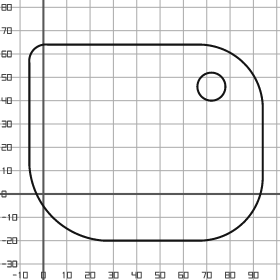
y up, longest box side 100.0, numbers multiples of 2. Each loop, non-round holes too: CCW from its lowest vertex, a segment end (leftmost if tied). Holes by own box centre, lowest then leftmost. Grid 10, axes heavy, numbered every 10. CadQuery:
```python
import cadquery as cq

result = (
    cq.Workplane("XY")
    .moveTo(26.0, -20.0)
    .lineTo(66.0, -20.0)
    .threePointArc((86.0, -12.0), (94.0, 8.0))
    .lineTo(94.0, 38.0)
    .threePointArc((86.0, 56.0), (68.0, 64.0))
    .lineTo(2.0, 64.0)
    .threePointArc((-4.0, 62.0), (-6.0, 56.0))
    .lineTo(-6.0, 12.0)
    .threePointArc((4.0, -10.0), (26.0, -20.0))
    .close()
    .moveTo(72.0, 46.0)
    .circle(6.0)
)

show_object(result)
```